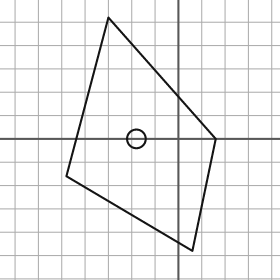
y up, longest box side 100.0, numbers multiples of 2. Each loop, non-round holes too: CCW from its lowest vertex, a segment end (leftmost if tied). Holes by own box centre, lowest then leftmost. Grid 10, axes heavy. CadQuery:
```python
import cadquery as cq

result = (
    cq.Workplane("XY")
    .moveTo(6.0, -48.0)
    .lineTo(16.0, 0.0)
    .lineTo(-30.0, 52.0)
    .lineTo(-48.0, -16.0)
    .close()
    .moveTo(-18.0, 0.0)
    .circle(4.0)
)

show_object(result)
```